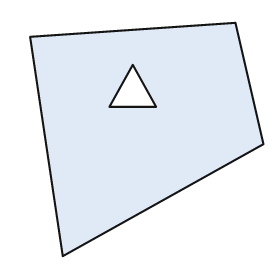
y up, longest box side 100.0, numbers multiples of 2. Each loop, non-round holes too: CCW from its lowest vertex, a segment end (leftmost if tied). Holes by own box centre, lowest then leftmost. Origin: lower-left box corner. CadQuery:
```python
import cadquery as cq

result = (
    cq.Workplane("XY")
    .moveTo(14.0, 0.0)
    .lineTo(100.0, 48.0)
    .lineTo(88.0, 100.0)
    .lineTo(0.0, 94.0)
    .close()
    .moveTo(34.0, 64.0)
    .lineTo(54.0, 64.0)
    .lineTo(44.0, 82.0)
    .close()
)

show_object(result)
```